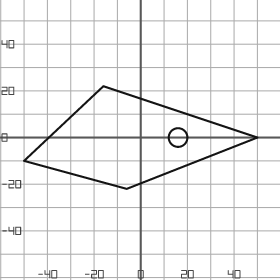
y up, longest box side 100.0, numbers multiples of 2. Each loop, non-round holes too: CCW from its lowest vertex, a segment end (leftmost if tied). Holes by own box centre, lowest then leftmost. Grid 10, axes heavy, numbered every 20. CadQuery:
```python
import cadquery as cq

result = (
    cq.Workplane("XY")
    .moveTo(-6.0, -22.0)
    .lineTo(50.0, 0.0)
    .lineTo(-16.0, 22.0)
    .lineTo(-50.0, -10.0)
    .close()
    .moveTo(16.0, 0.0)
    .circle(4.0)
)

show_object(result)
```